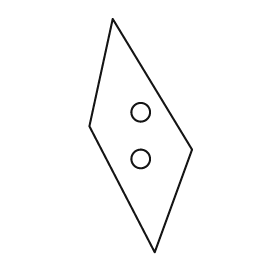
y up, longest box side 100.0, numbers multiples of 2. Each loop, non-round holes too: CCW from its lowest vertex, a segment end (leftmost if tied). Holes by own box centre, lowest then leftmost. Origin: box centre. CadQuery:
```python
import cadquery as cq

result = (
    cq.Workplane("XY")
    .moveTo(6.0, -50.0)
    .lineTo(22.0, -6.0)
    .lineTo(-12.0, 50.0)
    .lineTo(-22.0, 4.0)
    .close()
    .moveTo(0.0, -10.0)
    .circle(4.0)
    .moveTo(0.0, 10.0)
    .circle(4.0)
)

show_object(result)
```